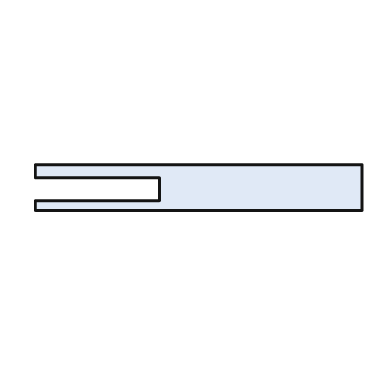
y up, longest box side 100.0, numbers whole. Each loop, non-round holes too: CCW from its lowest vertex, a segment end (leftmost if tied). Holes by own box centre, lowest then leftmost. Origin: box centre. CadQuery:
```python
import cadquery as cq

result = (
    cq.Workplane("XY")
    .moveTo(-50.0, -7.0)
    .lineTo(50.0, -7.0)
    .lineTo(50.0, 7.0)
    .lineTo(-50.0, 7.0)
    .lineTo(-50.0, 3.0)
    .lineTo(-12.0, 3.0)
    .lineTo(-12.0, -4.0)
    .lineTo(-50.0, -4.0)
    .close()
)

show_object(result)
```